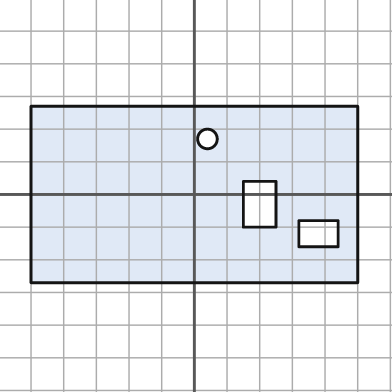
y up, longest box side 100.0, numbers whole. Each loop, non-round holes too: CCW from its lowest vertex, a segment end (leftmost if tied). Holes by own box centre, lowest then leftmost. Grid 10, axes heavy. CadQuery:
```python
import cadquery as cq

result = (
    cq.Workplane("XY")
    .moveTo(-50.0, -27.0)
    .lineTo(50.0, -27.0)
    .lineTo(50.0, 27.0)
    .lineTo(-50.0, 27.0)
    .close()
    .moveTo(32.0, -16.0)
    .lineTo(44.0, -16.0)
    .lineTo(44.0, -8.0)
    .lineTo(32.0, -8.0)
    .close()
    .moveTo(15.0, -10.0)
    .lineTo(25.0, -10.0)
    .lineTo(25.0, 4.0)
    .lineTo(15.0, 4.0)
    .close()
    .moveTo(4.0, 17.0)
    .circle(3.0)
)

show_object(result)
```